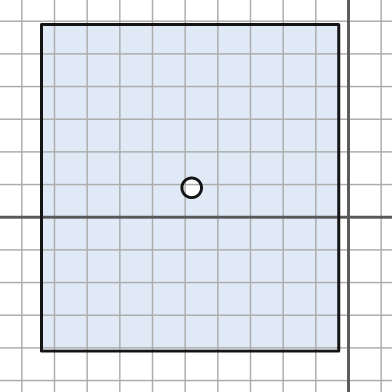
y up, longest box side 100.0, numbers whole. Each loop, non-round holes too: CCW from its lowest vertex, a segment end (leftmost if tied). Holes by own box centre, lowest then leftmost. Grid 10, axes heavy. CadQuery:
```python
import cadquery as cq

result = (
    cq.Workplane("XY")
    .moveTo(-94.0, -41.0)
    .lineTo(-3.0, -41.0)
    .lineTo(-3.0, 59.0)
    .lineTo(-94.0, 59.0)
    .close()
    .moveTo(-48.0, 9.0)
    .circle(3.0)
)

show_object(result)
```